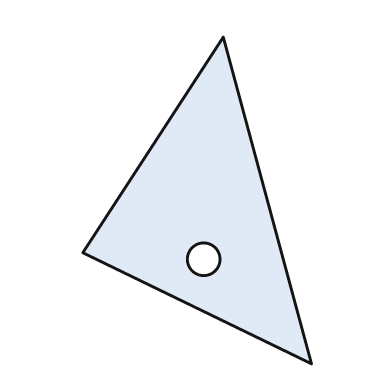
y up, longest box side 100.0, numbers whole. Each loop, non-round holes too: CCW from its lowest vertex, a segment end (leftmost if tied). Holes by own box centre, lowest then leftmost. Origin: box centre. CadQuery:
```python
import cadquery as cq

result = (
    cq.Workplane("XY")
    .moveTo(35.0, -50.0)
    .lineTo(8.0, 50.0)
    .lineTo(-35.0, -16.0)
    .close()
    .moveTo(2.0, -18.0)
    .circle(5.0)
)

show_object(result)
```